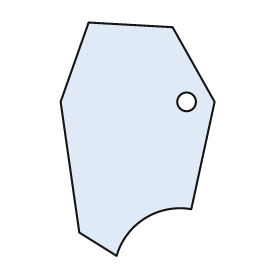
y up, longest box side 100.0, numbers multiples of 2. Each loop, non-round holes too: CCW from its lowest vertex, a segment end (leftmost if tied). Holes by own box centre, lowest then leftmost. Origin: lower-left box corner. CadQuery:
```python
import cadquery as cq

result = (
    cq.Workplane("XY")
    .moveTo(24.0, 0.0)
    .threePointArc((36.0, 16.0), (56.0, 20.0))
    .lineTo(66.0, 66.0)
    .lineTo(48.0, 98.0)
    .lineTo(12.0, 100.0)
    .lineTo(0.0, 66.0)
    .lineTo(8.0, 10.0)
    .close()
    .moveTo(54.0, 66.0)
    .circle(4.0)
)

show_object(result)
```